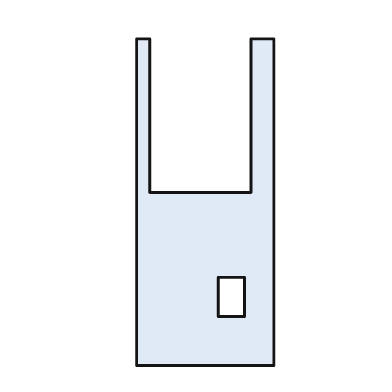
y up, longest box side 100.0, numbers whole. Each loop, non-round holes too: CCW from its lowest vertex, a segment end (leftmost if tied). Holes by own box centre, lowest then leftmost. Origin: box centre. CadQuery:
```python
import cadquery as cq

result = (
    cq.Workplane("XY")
    .moveTo(-21.0, -50.0)
    .lineTo(21.0, -50.0)
    .lineTo(21.0, 50.0)
    .lineTo(14.0, 50.0)
    .lineTo(14.0, 3.0)
    .lineTo(-17.0, 3.0)
    .lineTo(-17.0, 50.0)
    .lineTo(-21.0, 50.0)
    .close()
    .moveTo(4.0, -35.0)
    .lineTo(12.0, -35.0)
    .lineTo(12.0, -23.0)
    .lineTo(4.0, -23.0)
    .close()
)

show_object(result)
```